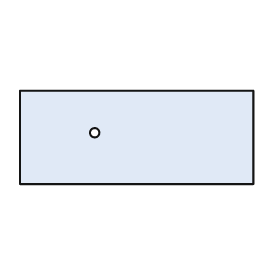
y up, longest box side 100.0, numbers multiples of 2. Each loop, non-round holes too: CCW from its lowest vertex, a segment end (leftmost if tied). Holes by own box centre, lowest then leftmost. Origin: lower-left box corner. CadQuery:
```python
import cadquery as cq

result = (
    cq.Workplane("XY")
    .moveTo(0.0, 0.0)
    .lineTo(100.0, 0.0)
    .lineTo(100.0, 40.0)
    .lineTo(0.0, 40.0)
    .close()
    .moveTo(32.0, 22.0)
    .circle(2.0)
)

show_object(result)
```